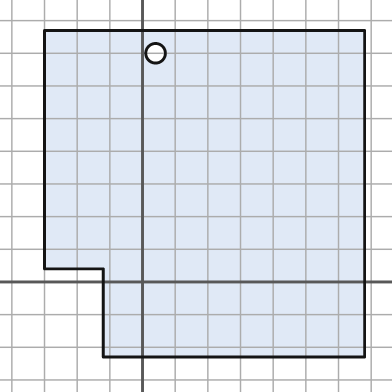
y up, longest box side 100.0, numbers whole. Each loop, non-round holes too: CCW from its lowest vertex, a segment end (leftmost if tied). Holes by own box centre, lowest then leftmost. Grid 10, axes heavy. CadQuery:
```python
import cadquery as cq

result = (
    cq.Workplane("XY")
    .moveTo(-12.0, -23.0)
    .lineTo(68.0, -23.0)
    .lineTo(68.0, 77.0)
    .lineTo(-30.0, 77.0)
    .lineTo(-30.0, 4.0)
    .lineTo(-12.0, 4.0)
    .close()
    .moveTo(4.0, 70.0)
    .circle(3.0)
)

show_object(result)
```